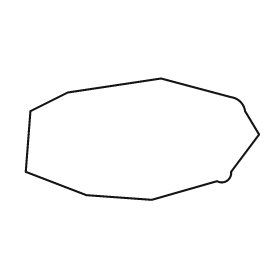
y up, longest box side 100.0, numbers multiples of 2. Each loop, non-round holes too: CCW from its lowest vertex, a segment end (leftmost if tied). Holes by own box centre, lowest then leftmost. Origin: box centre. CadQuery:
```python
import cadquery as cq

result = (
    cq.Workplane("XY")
    .moveTo(4.0, -26.0)
    .lineTo(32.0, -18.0)
    .threePointArc((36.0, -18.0), (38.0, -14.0))
    .lineTo(50.0, 2.0)
    .lineTo(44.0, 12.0)
    .threePointArc((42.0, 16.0), (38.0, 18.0))
    .lineTo(8.0, 26.0)
    .lineTo(-32.0, 20.0)
    .lineTo(-48.0, 12.0)
    .lineTo(-50.0, -14.0)
    .lineTo(-24.0, -24.0)
    .close()
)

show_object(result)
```